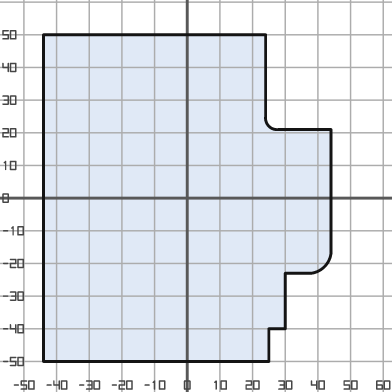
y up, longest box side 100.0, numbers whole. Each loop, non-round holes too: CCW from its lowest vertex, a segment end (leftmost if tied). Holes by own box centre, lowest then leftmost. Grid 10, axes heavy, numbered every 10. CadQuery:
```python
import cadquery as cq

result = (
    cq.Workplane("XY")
    .moveTo(-44.0, -50.0)
    .lineTo(25.0, -50.0)
    .lineTo(25.0, -40.0)
    .lineTo(30.0, -40.0)
    .lineTo(30.0, -23.0)
    .lineTo(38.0, -23.0)
    .threePointArc((42.0, -21.0), (44.0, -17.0))
    .lineTo(44.0, 21.0)
    .lineTo(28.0, 21.0)
    .threePointArc((25.0, 22.0), (24.0, 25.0))
    .lineTo(24.0, 50.0)
    .lineTo(-44.0, 50.0)
    .close()
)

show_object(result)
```